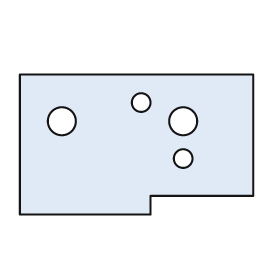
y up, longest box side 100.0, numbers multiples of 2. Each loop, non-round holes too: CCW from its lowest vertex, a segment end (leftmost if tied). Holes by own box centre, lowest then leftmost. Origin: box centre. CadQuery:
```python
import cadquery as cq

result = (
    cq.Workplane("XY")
    .moveTo(-50.0, -30.0)
    .lineTo(6.0, -30.0)
    .lineTo(6.0, -22.0)
    .lineTo(50.0, -22.0)
    .lineTo(50.0, 30.0)
    .lineTo(-50.0, 30.0)
    .close()
    .moveTo(20.0, -6.0)
    .circle(4.0)
    .moveTo(-32.0, 10.0)
    .circle(6.0)
    .moveTo(20.0, 10.0)
    .circle(6.0)
    .moveTo(2.0, 18.0)
    .circle(4.0)
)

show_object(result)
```